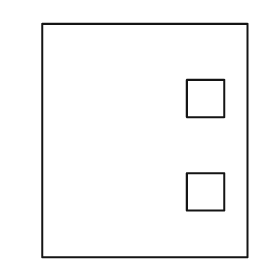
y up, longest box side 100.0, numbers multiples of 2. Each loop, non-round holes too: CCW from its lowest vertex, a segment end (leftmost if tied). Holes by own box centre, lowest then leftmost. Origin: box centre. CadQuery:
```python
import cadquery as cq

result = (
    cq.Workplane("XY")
    .moveTo(-44.0, -50.0)
    .lineTo(44.0, -50.0)
    .lineTo(44.0, 50.0)
    .lineTo(-44.0, 50.0)
    .close()
    .moveTo(18.0, -30.0)
    .lineTo(34.0, -30.0)
    .lineTo(34.0, -14.0)
    .lineTo(18.0, -14.0)
    .close()
    .moveTo(18.0, 10.0)
    .lineTo(34.0, 10.0)
    .lineTo(34.0, 26.0)
    .lineTo(18.0, 26.0)
    .close()
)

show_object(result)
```